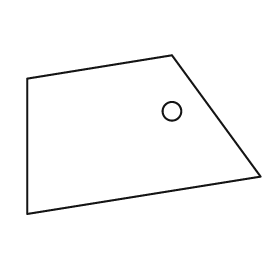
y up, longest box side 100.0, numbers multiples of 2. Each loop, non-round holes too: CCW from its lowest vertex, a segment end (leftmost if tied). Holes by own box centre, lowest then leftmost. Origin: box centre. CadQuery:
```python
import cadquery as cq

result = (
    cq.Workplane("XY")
    .moveTo(-50.0, -34.0)
    .lineTo(50.0, -18.0)
    .lineTo(12.0, 34.0)
    .lineTo(-50.0, 24.0)
    .close()
    .moveTo(12.0, 10.0)
    .circle(4.0)
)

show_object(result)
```